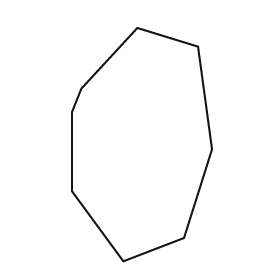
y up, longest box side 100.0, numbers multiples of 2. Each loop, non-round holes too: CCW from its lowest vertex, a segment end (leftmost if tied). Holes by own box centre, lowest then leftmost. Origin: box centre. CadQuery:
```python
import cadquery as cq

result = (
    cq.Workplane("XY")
    .moveTo(-8.0, -50.0)
    .lineTo(18.0, -40.0)
    .lineTo(30.0, -2.0)
    .lineTo(24.0, 42.0)
    .lineTo(-2.0, 50.0)
    .lineTo(-26.0, 24.0)
    .lineTo(-30.0, 14.0)
    .lineTo(-30.0, -20.0)
    .close()
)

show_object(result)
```